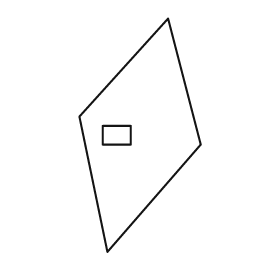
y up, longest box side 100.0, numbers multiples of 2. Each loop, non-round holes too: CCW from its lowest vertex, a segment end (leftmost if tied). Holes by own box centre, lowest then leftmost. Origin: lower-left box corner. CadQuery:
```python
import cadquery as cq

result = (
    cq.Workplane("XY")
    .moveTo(12.0, 0.0)
    .lineTo(52.0, 46.0)
    .lineTo(38.0, 100.0)
    .lineTo(0.0, 58.0)
    .close()
    .moveTo(10.0, 46.0)
    .lineTo(22.0, 46.0)
    .lineTo(22.0, 54.0)
    .lineTo(10.0, 54.0)
    .close()
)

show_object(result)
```